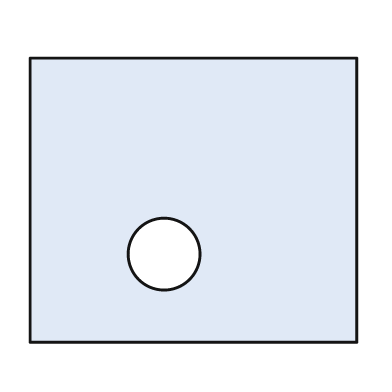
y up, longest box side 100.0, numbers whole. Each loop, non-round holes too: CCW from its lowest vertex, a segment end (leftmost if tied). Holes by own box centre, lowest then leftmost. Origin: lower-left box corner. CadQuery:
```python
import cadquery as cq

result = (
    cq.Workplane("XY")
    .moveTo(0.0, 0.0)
    .lineTo(100.0, 0.0)
    .lineTo(100.0, 87.0)
    .lineTo(0.0, 87.0)
    .close()
    .moveTo(41.0, 27.0)
    .circle(11.0)
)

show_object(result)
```